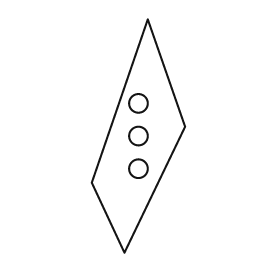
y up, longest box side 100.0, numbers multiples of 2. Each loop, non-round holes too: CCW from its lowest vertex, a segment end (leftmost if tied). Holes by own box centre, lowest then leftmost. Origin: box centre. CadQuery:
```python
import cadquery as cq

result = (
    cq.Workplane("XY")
    .moveTo(-6.0, -50.0)
    .lineTo(20.0, 4.0)
    .lineTo(4.0, 50.0)
    .lineTo(-20.0, -20.0)
    .close()
    .moveTo(0.0, -14.0)
    .circle(4.0)
    .moveTo(0.0, 0.0)
    .circle(4.0)
    .moveTo(0.0, 14.0)
    .circle(4.0)
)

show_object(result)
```